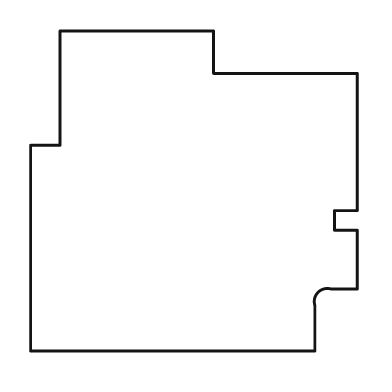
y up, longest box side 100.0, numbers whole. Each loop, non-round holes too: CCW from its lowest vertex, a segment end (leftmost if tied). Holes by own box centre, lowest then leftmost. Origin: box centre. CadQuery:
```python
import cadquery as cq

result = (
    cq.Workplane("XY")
    .moveTo(-50.0, -49.0)
    .lineTo(37.0, -49.0)
    .lineTo(37.0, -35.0)
    .threePointArc((38.0, -31.0), (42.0, -30.0))
    .lineTo(50.0, -30.0)
    .lineTo(50.0, -12.0)
    .lineTo(43.0, -12.0)
    .lineTo(43.0, -6.0)
    .lineTo(50.0, -6.0)
    .lineTo(50.0, 36.0)
    .lineTo(6.0, 36.0)
    .lineTo(6.0, 49.0)
    .lineTo(-41.0, 49.0)
    .lineTo(-41.0, 14.0)
    .lineTo(-50.0, 14.0)
    .close()
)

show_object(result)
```